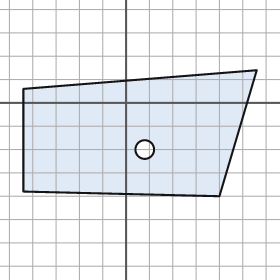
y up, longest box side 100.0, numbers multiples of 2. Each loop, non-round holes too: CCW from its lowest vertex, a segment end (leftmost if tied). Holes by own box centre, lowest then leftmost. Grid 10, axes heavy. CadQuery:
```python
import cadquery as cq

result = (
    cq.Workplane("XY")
    .moveTo(40.0, -40.0)
    .lineTo(56.0, 14.0)
    .lineTo(-44.0, 6.0)
    .lineTo(-44.0, -38.0)
    .close()
    .moveTo(8.0, -20.0)
    .circle(4.0)
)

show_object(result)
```